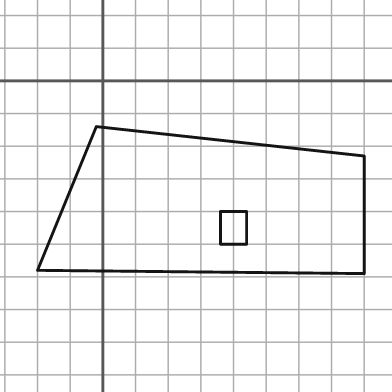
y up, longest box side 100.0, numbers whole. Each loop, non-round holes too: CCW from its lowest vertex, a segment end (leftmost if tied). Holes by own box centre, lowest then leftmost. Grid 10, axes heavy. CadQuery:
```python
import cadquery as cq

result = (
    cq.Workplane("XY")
    .moveTo(80.0, -59.0)
    .lineTo(80.0, -23.0)
    .lineTo(-2.0, -14.0)
    .lineTo(-20.0, -58.0)
    .close()
    .moveTo(36.0, -50.0)
    .lineTo(44.0, -50.0)
    .lineTo(44.0, -40.0)
    .lineTo(36.0, -40.0)
    .close()
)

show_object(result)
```